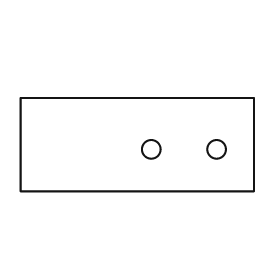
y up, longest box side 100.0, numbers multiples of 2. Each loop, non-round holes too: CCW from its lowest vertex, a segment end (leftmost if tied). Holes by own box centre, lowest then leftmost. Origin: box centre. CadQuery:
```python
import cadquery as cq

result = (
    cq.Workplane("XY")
    .moveTo(-50.0, -20.0)
    .lineTo(50.0, -20.0)
    .lineTo(50.0, 20.0)
    .lineTo(-50.0, 20.0)
    .close()
    .moveTo(6.0, -2.0)
    .circle(4.0)
    .moveTo(34.0, -2.0)
    .circle(4.0)
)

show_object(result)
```